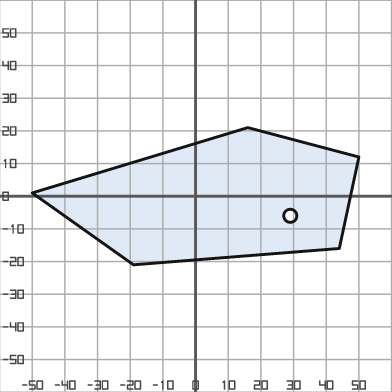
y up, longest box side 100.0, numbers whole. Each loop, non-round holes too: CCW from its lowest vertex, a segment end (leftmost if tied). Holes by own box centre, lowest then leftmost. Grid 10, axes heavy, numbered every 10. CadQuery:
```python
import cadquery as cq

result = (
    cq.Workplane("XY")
    .moveTo(-19.0, -21.0)
    .lineTo(44.0, -16.0)
    .lineTo(50.0, 12.0)
    .lineTo(16.0, 21.0)
    .lineTo(-50.0, 1.0)
    .close()
    .moveTo(29.0, -6.0)
    .circle(2.0)
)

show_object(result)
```